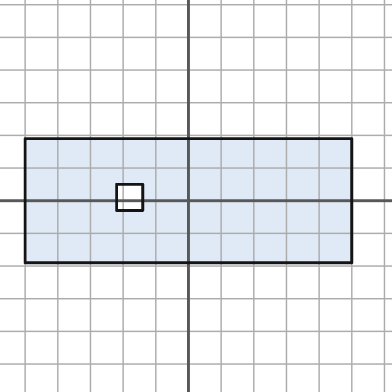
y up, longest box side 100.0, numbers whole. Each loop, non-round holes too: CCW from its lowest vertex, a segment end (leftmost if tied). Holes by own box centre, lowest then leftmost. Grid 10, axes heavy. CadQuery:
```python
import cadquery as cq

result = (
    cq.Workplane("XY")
    .moveTo(-50.0, -19.0)
    .lineTo(50.0, -19.0)
    .lineTo(50.0, 19.0)
    .lineTo(-50.0, 19.0)
    .close()
    .moveTo(-22.0, -3.0)
    .lineTo(-14.0, -3.0)
    .lineTo(-14.0, 5.0)
    .lineTo(-22.0, 5.0)
    .close()
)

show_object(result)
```